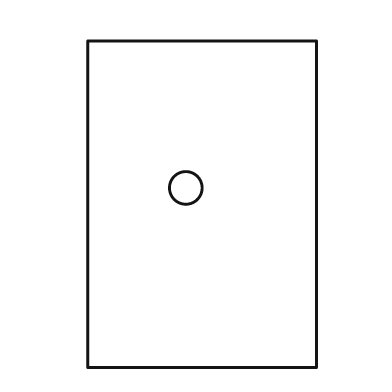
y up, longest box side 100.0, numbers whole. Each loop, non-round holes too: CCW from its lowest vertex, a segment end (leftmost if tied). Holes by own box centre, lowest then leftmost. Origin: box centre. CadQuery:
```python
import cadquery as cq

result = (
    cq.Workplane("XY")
    .moveTo(-35.0, -50.0)
    .lineTo(35.0, -50.0)
    .lineTo(35.0, 50.0)
    .lineTo(-35.0, 50.0)
    .close()
    .moveTo(-5.0, 5.0)
    .circle(5.0)
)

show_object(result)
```